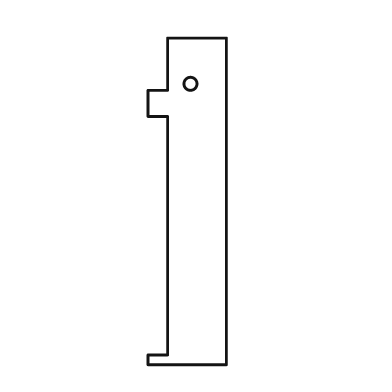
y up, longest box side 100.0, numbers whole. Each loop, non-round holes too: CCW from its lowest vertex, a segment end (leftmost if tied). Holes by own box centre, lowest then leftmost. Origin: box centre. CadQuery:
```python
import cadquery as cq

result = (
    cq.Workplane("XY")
    .moveTo(-12.0, -50.0)
    .lineTo(12.0, -50.0)
    .lineTo(12.0, 50.0)
    .lineTo(-6.0, 50.0)
    .lineTo(-6.0, 34.0)
    .lineTo(-12.0, 34.0)
    .lineTo(-12.0, 26.0)
    .lineTo(-6.0, 26.0)
    .lineTo(-6.0, -47.0)
    .lineTo(-12.0, -47.0)
    .close()
    .moveTo(1.0, 36.0)
    .circle(2.0)
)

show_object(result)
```